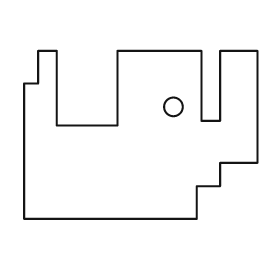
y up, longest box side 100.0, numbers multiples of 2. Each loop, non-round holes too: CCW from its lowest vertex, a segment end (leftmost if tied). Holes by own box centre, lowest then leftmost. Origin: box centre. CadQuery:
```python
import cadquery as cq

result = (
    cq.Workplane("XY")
    .moveTo(-50.0, -36.0)
    .lineTo(24.0, -36.0)
    .lineTo(24.0, -22.0)
    .lineTo(34.0, -22.0)
    .lineTo(34.0, -12.0)
    .lineTo(50.0, -12.0)
    .lineTo(50.0, 36.0)
    .lineTo(34.0, 36.0)
    .lineTo(34.0, 6.0)
    .lineTo(26.0, 6.0)
    .lineTo(26.0, 36.0)
    .lineTo(-10.0, 36.0)
    .lineTo(-10.0, 4.0)
    .lineTo(-36.0, 4.0)
    .lineTo(-36.0, 36.0)
    .lineTo(-44.0, 36.0)
    .lineTo(-44.0, 22.0)
    .lineTo(-50.0, 22.0)
    .close()
    .moveTo(14.0, 12.0)
    .circle(4.0)
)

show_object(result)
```